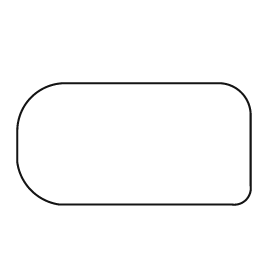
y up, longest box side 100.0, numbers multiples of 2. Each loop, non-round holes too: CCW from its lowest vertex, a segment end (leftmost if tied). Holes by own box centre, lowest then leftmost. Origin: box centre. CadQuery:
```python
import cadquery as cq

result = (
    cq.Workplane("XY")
    .moveTo(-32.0, -26.0)
    .lineTo(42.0, -26.0)
    .threePointArc((48.0, -24.0), (50.0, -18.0))
    .lineTo(50.0, 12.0)
    .threePointArc((46.0, 22.0), (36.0, 26.0))
    .lineTo(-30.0, 26.0)
    .threePointArc((-44.0, 20.0), (-50.0, 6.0))
    .lineTo(-50.0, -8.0)
    .threePointArc((-44.0, -20.0), (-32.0, -26.0))
    .close()
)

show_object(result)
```